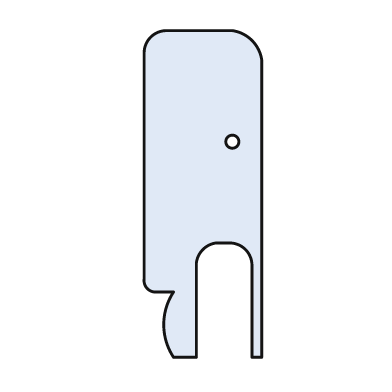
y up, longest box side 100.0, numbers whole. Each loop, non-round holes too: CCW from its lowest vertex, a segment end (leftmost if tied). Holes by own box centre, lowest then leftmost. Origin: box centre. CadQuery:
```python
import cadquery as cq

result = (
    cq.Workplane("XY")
    .moveTo(-9.0, -50.0)
    .lineTo(-2.0, -50.0)
    .lineTo(-2.0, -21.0)
    .threePointArc((0.0, -17.0), (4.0, -15.0))
    .lineTo(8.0, -15.0)
    .threePointArc((13.0, -17.0), (15.0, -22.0))
    .lineTo(15.0, -50.0)
    .lineTo(18.0, -50.0)
    .lineTo(18.0, 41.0)
    .threePointArc((15.0, 47.0), (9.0, 50.0))
    .lineTo(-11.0, 50.0)
    .threePointArc((-16.0, 48.0), (-18.0, 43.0))
    .lineTo(-18.0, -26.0)
    .threePointArc((-17.0, -29.0), (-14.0, -30.0))
    .lineTo(-9.0, -30.0)
    .threePointArc((-12.0, -40.0), (-9.0, -50.0))
    .close()
    .moveTo(9.0, 16.0)
    .circle(2.0)
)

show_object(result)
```